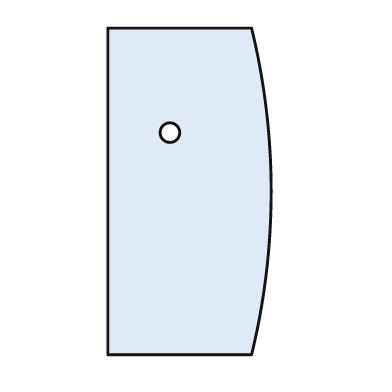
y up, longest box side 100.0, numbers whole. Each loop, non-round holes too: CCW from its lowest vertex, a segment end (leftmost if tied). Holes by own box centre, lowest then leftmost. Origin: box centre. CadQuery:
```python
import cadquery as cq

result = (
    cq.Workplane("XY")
    .moveTo(-25.0, -50.0)
    .lineTo(19.0, -50.0)
    .threePointArc((25.0, 0.0), (19.0, 50.0))
    .lineTo(-25.0, 50.0)
    .close()
    .moveTo(-6.0, 18.0)
    .circle(3.0)
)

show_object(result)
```